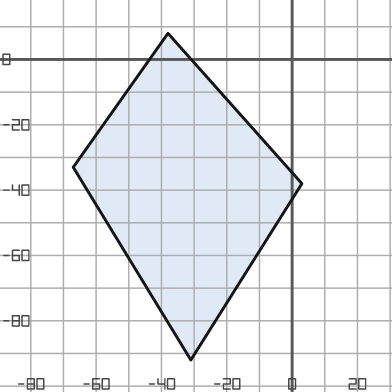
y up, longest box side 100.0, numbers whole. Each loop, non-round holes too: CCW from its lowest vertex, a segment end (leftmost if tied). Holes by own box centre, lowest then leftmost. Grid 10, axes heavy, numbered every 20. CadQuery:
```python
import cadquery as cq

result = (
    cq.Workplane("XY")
    .moveTo(-31.0, -92.0)
    .lineTo(3.0, -38.0)
    .lineTo(-38.0, 8.0)
    .lineTo(-67.0, -33.0)
    .close()
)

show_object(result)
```